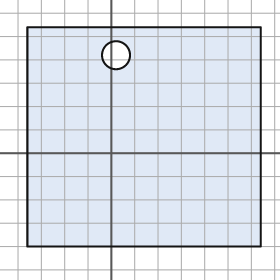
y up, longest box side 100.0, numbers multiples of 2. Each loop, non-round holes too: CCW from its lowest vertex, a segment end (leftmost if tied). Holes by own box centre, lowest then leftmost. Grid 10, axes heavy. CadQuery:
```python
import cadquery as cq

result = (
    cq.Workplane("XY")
    .moveTo(-36.0, -40.0)
    .lineTo(64.0, -40.0)
    .lineTo(64.0, 54.0)
    .lineTo(-36.0, 54.0)
    .close()
    .moveTo(2.0, 42.0)
    .circle(6.0)
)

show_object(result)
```